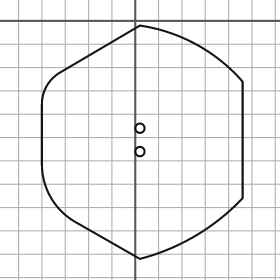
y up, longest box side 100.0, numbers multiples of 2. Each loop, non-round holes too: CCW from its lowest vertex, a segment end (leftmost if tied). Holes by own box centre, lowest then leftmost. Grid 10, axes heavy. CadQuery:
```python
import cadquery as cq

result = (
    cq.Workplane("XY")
    .moveTo(2.0, -102.0)
    .threePointArc((26.0, -92.0), (46.0, -76.0))
    .lineTo(46.0, -26.0)
    .threePointArc((26.0, -10.0), (2.0, -2.0))
    .lineTo(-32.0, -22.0)
    .threePointArc((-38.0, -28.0), (-40.0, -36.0))
    .lineTo(-40.0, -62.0)
    .threePointArc((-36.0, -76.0), (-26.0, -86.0))
    .close()
    .moveTo(2.0, -56.0)
    .circle(2.0)
    .moveTo(2.0, -46.0)
    .circle(2.0)
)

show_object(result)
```